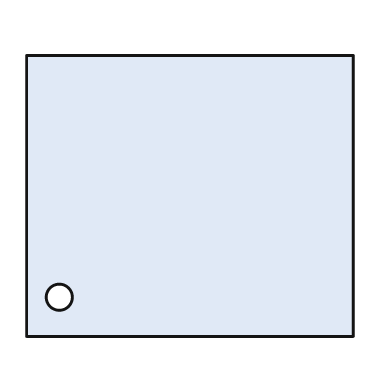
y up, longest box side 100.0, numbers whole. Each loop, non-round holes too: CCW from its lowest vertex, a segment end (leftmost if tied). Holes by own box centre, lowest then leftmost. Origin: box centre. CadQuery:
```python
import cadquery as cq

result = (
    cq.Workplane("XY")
    .moveTo(-50.0, -43.0)
    .lineTo(50.0, -43.0)
    .lineTo(50.0, 43.0)
    .lineTo(-50.0, 43.0)
    .close()
    .moveTo(-40.0, -31.0)
    .circle(4.0)
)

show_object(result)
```